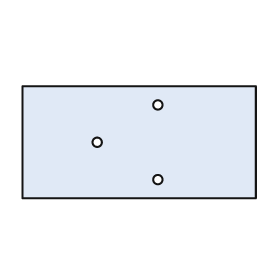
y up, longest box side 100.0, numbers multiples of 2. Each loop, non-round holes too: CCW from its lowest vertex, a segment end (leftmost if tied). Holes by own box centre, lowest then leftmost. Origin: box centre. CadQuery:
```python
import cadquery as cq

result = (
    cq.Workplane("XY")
    .moveTo(-50.0, -24.0)
    .lineTo(50.0, -24.0)
    .lineTo(50.0, 24.0)
    .lineTo(-50.0, 24.0)
    .close()
    .moveTo(8.0, -16.0)
    .circle(2.0)
    .moveTo(-18.0, 0.0)
    .circle(2.0)
    .moveTo(8.0, 16.0)
    .circle(2.0)
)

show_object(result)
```